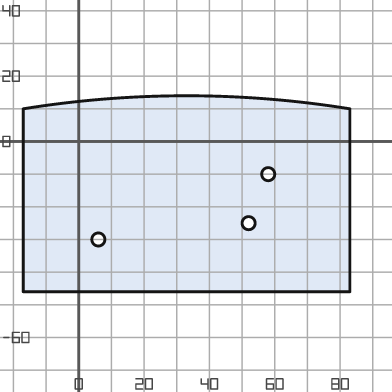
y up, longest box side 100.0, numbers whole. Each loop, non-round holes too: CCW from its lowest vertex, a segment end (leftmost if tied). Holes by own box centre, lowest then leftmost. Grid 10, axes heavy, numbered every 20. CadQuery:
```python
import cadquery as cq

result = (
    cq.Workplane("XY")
    .moveTo(-17.0, -46.0)
    .lineTo(83.0, -46.0)
    .lineTo(83.0, 10.0)
    .threePointArc((33.0, 14.0), (-17.0, 10.0))
    .close()
    .moveTo(6.0, -30.0)
    .circle(2.0)
    .moveTo(52.0, -25.0)
    .circle(2.0)
    .moveTo(58.0, -10.0)
    .circle(2.0)
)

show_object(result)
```